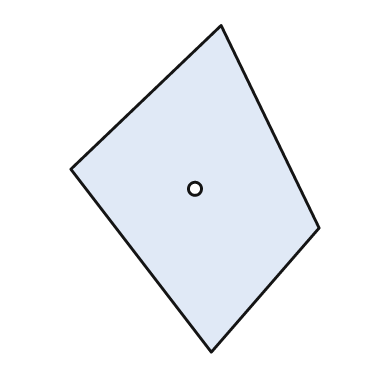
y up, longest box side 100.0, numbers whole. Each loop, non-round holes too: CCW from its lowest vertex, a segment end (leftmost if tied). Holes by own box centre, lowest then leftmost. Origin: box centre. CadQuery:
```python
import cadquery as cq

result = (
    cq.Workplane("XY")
    .moveTo(5.0, -50.0)
    .lineTo(38.0, -12.0)
    .lineTo(8.0, 50.0)
    .lineTo(-38.0, 6.0)
    .close()
    .moveTo(0.0, 0.0)
    .circle(2.0)
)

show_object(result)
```